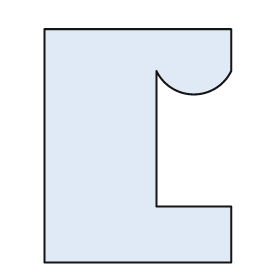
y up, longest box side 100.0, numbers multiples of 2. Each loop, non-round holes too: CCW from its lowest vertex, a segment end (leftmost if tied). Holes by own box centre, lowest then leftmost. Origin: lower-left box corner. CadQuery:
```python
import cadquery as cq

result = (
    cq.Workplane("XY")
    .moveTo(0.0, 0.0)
    .lineTo(80.0, 0.0)
    .lineTo(80.0, 24.0)
    .lineTo(48.0, 24.0)
    .lineTo(48.0, 82.0)
    .threePointArc((64.0, 72.0), (80.0, 82.0))
    .lineTo(80.0, 100.0)
    .lineTo(0.0, 100.0)
    .close()
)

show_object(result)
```